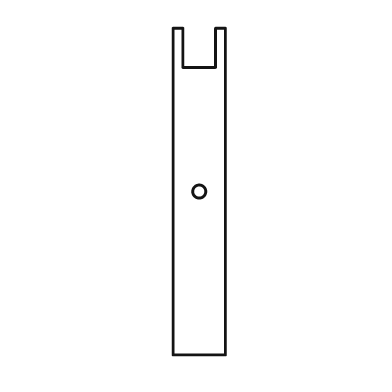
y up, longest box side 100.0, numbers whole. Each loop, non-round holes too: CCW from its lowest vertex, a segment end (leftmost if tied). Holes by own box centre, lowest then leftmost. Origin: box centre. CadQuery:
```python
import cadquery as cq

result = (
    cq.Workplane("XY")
    .moveTo(-8.0, -50.0)
    .lineTo(8.0, -50.0)
    .lineTo(8.0, 50.0)
    .lineTo(5.0, 50.0)
    .lineTo(5.0, 38.0)
    .lineTo(-5.0, 38.0)
    .lineTo(-5.0, 50.0)
    .lineTo(-8.0, 50.0)
    .close()
    .moveTo(0.0, 0.0)
    .circle(2.0)
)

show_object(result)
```